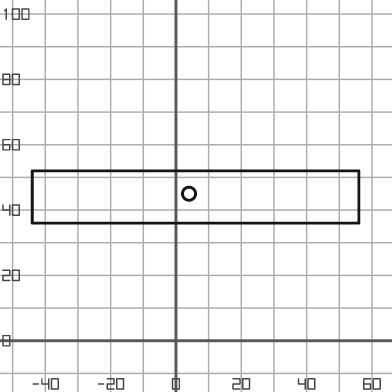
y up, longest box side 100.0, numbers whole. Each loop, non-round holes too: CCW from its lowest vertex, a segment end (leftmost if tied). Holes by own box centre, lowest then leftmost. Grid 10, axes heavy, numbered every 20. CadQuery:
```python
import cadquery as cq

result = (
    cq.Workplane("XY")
    .moveTo(-44.0, 36.0)
    .lineTo(56.0, 36.0)
    .lineTo(56.0, 52.0)
    .lineTo(-44.0, 52.0)
    .close()
    .moveTo(4.0, 45.0)
    .circle(2.0)
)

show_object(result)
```